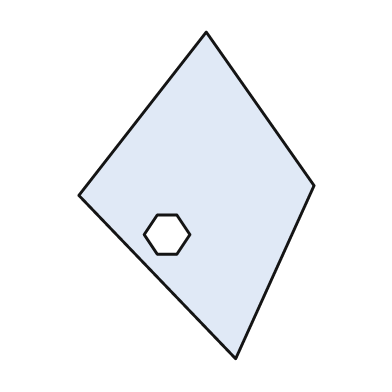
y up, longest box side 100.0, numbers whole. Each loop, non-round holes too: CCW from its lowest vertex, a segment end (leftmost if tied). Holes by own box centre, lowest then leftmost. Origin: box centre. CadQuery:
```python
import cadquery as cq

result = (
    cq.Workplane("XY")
    .moveTo(12.0, -50.0)
    .lineTo(36.0, 3.0)
    .lineTo(3.0, 50.0)
    .lineTo(-36.0, 0.0)
    .close()
    .moveTo(-12.0, -18.0)
    .lineTo(-6.0, -18.0)
    .lineTo(-2.0, -12.0)
    .lineTo(-6.0, -6.0)
    .lineTo(-12.0, -6.0)
    .lineTo(-16.0, -12.0)
    .close()
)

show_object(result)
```